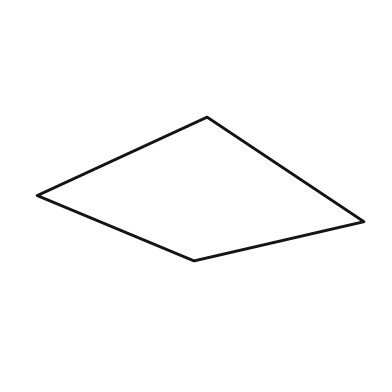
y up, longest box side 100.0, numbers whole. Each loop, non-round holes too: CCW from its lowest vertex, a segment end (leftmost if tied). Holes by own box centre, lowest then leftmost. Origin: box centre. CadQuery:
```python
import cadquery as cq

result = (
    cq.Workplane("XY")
    .moveTo(-2.0, -22.0)
    .lineTo(50.0, -10.0)
    .lineTo(2.0, 22.0)
    .lineTo(-50.0, -2.0)
    .close()
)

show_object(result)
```